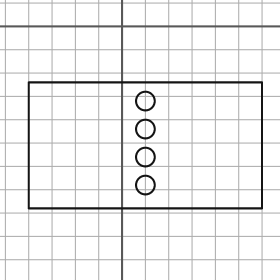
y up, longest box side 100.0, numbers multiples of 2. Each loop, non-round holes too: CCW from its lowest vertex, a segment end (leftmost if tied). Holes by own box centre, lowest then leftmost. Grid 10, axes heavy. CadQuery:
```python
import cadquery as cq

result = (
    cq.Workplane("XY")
    .moveTo(-40.0, -78.0)
    .lineTo(60.0, -78.0)
    .lineTo(60.0, -24.0)
    .lineTo(-40.0, -24.0)
    .close()
    .moveTo(10.0, -68.0)
    .circle(4.0)
    .moveTo(10.0, -56.0)
    .circle(4.0)
    .moveTo(10.0, -44.0)
    .circle(4.0)
    .moveTo(10.0, -32.0)
    .circle(4.0)
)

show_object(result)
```